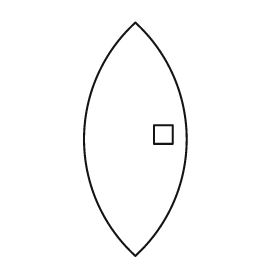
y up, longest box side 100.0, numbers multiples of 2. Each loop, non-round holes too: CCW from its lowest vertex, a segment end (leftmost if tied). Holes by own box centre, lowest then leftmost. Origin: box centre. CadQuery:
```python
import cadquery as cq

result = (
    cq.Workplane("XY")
    .moveTo(0.0, -50.0)
    .threePointArc((22.0, 0.0), (0.0, 50.0))
    .threePointArc((-22.0, 0.0), (0.0, -50.0))
    .close()
    .moveTo(8.0, -2.0)
    .lineTo(16.0, -2.0)
    .lineTo(16.0, 6.0)
    .lineTo(8.0, 6.0)
    .close()
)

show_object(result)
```